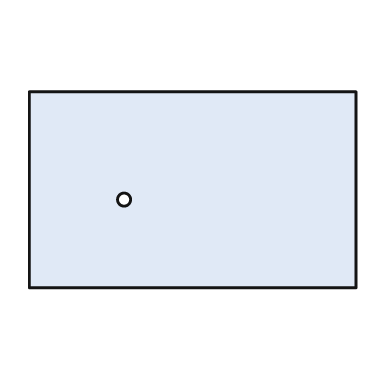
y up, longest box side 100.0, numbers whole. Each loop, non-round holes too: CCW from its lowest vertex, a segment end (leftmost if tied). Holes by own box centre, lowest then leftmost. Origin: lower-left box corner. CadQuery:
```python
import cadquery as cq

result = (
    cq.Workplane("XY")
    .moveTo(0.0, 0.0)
    .lineTo(100.0, 0.0)
    .lineTo(100.0, 60.0)
    .lineTo(0.0, 60.0)
    .close()
    .moveTo(29.0, 27.0)
    .circle(2.0)
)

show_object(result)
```